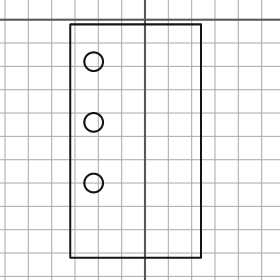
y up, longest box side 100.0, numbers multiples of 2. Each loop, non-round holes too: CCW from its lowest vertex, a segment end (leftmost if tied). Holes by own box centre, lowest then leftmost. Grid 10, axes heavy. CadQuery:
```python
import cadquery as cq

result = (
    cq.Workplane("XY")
    .moveTo(-32.0, -102.0)
    .lineTo(24.0, -102.0)
    .lineTo(24.0, -2.0)
    .lineTo(-32.0, -2.0)
    .close()
    .moveTo(-22.0, -70.0)
    .circle(4.0)
    .moveTo(-22.0, -44.0)
    .circle(4.0)
    .moveTo(-22.0, -18.0)
    .circle(4.0)
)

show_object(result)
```